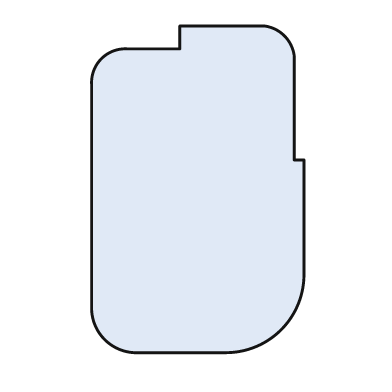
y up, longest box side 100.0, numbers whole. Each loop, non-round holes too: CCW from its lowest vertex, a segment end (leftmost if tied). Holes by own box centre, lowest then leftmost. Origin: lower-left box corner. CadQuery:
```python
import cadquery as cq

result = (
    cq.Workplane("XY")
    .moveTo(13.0, 0.0)
    .lineTo(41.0, 0.0)
    .threePointArc((58.0, 7.0), (65.0, 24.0))
    .lineTo(65.0, 59.0)
    .lineTo(62.0, 59.0)
    .lineTo(62.0, 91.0)
    .threePointArc((59.0, 97.0), (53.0, 100.0))
    .lineTo(27.0, 100.0)
    .lineTo(27.0, 93.0)
    .lineTo(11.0, 93.0)
    .threePointArc((3.0, 90.0), (0.0, 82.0))
    .lineTo(0.0, 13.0)
    .threePointArc((4.0, 4.0), (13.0, 0.0))
    .close()
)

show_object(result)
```